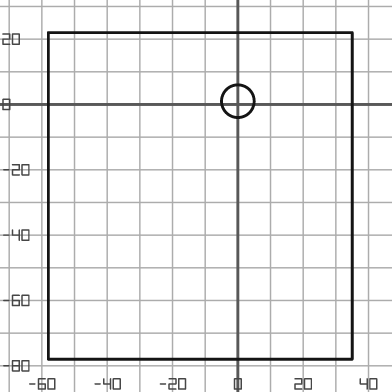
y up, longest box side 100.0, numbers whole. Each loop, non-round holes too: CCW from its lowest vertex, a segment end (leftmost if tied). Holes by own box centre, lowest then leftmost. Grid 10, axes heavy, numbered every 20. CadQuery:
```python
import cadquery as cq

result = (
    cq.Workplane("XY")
    .moveTo(-58.0, -78.0)
    .lineTo(35.0, -78.0)
    .lineTo(35.0, 22.0)
    .lineTo(-58.0, 22.0)
    .close()
    .moveTo(0.0, 1.0)
    .circle(5.0)
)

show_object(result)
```